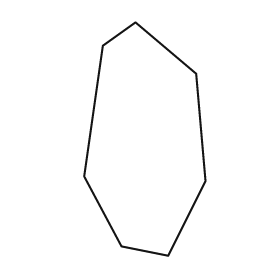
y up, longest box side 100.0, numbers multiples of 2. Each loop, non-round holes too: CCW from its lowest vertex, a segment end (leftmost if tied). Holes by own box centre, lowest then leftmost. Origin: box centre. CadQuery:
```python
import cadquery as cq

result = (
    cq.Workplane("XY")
    .moveTo(10.0, -50.0)
    .lineTo(26.0, -18.0)
    .lineTo(22.0, 28.0)
    .lineTo(-4.0, 50.0)
    .lineTo(-18.0, 40.0)
    .lineTo(-26.0, -16.0)
    .lineTo(-10.0, -46.0)
    .close()
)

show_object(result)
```